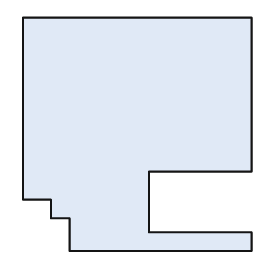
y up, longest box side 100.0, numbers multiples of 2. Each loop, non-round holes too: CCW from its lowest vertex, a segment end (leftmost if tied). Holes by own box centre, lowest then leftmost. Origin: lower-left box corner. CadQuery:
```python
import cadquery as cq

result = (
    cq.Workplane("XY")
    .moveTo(20.0, 0.0)
    .lineTo(98.0, 0.0)
    .lineTo(98.0, 8.0)
    .lineTo(54.0, 8.0)
    .lineTo(54.0, 34.0)
    .lineTo(98.0, 34.0)
    .lineTo(98.0, 100.0)
    .lineTo(0.0, 100.0)
    .lineTo(0.0, 22.0)
    .lineTo(12.0, 22.0)
    .lineTo(12.0, 14.0)
    .lineTo(20.0, 14.0)
    .close()
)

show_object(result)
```